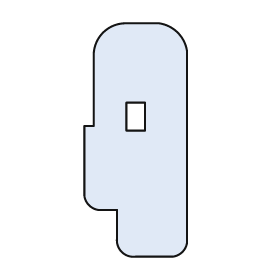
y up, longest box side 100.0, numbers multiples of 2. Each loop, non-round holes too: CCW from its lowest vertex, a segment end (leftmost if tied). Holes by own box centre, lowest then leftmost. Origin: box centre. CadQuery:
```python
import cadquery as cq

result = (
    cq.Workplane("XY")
    .moveTo(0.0, -50.0)
    .lineTo(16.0, -50.0)
    .threePointArc((20.0, -48.0), (22.0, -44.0))
    .lineTo(22.0, 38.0)
    .threePointArc((18.0, 46.0), (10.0, 50.0))
    .lineTo(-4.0, 50.0)
    .threePointArc((-14.0, 46.0), (-18.0, 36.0))
    .lineTo(-18.0, 6.0)
    .lineTo(-22.0, 6.0)
    .lineTo(-22.0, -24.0)
    .threePointArc((-20.0, -28.0), (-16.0, -30.0))
    .lineTo(-8.0, -30.0)
    .lineTo(-8.0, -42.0)
    .threePointArc((-6.0, -48.0), (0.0, -50.0))
    .close()
    .moveTo(-4.0, 4.0)
    .lineTo(4.0, 4.0)
    .lineTo(4.0, 16.0)
    .lineTo(-4.0, 16.0)
    .close()
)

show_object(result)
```